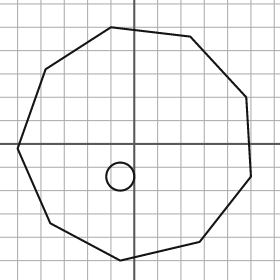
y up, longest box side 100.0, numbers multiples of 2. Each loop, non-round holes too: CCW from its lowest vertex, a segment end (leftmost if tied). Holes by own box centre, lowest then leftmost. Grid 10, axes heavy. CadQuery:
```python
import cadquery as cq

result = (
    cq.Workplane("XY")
    .moveTo(-6.0, -50.0)
    .lineTo(28.0, -42.0)
    .lineTo(50.0, -14.0)
    .lineTo(48.0, 20.0)
    .lineTo(24.0, 46.0)
    .lineTo(-10.0, 50.0)
    .lineTo(-38.0, 32.0)
    .lineTo(-50.0, -2.0)
    .lineTo(-36.0, -34.0)
    .close()
    .moveTo(-6.0, -14.0)
    .circle(6.0)
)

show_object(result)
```